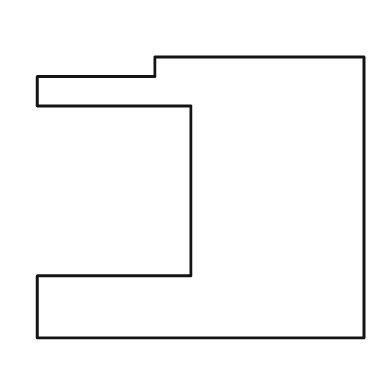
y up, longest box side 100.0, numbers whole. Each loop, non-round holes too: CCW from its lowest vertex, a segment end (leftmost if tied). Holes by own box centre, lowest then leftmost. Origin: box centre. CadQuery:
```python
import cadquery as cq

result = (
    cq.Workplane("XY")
    .moveTo(-50.0, -43.0)
    .lineTo(50.0, -43.0)
    .lineTo(50.0, 43.0)
    .lineTo(-14.0, 43.0)
    .lineTo(-14.0, 37.0)
    .lineTo(-50.0, 37.0)
    .lineTo(-50.0, 28.0)
    .lineTo(-3.0, 28.0)
    .lineTo(-3.0, -24.0)
    .lineTo(-50.0, -24.0)
    .close()
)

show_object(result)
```